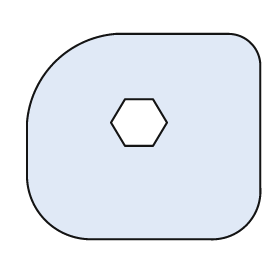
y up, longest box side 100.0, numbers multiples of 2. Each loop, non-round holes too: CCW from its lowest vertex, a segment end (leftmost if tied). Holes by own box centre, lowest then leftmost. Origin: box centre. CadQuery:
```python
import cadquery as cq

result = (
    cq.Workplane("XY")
    .moveTo(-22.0, -44.0)
    .lineTo(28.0, -44.0)
    .threePointArc((44.0, -38.0), (50.0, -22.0))
    .lineTo(50.0, 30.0)
    .threePointArc((46.0, 40.0), (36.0, 44.0))
    .lineTo(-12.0, 44.0)
    .threePointArc((-38.0, 32.0), (-50.0, 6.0))
    .lineTo(-50.0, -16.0)
    .threePointArc((-42.0, -36.0), (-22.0, -44.0))
    .close()
    .moveTo(-8.0, -4.0)
    .lineTo(4.0, -4.0)
    .lineTo(10.0, 6.0)
    .lineTo(4.0, 16.0)
    .lineTo(-8.0, 16.0)
    .lineTo(-14.0, 6.0)
    .close()
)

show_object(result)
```